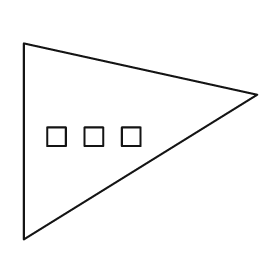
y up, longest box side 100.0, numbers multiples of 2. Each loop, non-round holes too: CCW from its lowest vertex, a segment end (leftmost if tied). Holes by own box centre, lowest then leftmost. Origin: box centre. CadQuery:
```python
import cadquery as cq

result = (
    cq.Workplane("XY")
    .moveTo(-50.0, -42.0)
    .lineTo(50.0, 20.0)
    .lineTo(-50.0, 42.0)
    .close()
    .moveTo(-40.0, -2.0)
    .lineTo(-32.0, -2.0)
    .lineTo(-32.0, 6.0)
    .lineTo(-40.0, 6.0)
    .close()
    .moveTo(-24.0, -2.0)
    .lineTo(-16.0, -2.0)
    .lineTo(-16.0, 6.0)
    .lineTo(-24.0, 6.0)
    .close()
    .moveTo(-8.0, -2.0)
    .lineTo(0.0, -2.0)
    .lineTo(0.0, 6.0)
    .lineTo(-8.0, 6.0)
    .close()
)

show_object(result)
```